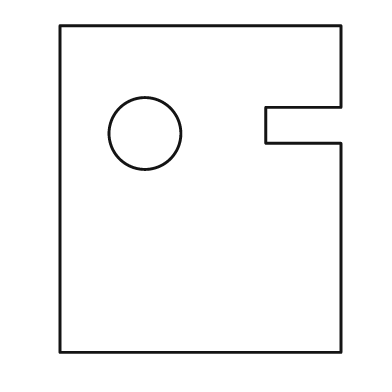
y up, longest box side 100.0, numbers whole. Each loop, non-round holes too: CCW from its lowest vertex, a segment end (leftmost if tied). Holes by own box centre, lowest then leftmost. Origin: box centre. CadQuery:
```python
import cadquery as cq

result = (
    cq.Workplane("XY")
    .moveTo(-43.0, -50.0)
    .lineTo(43.0, -50.0)
    .lineTo(43.0, 14.0)
    .lineTo(20.0, 14.0)
    .lineTo(20.0, 25.0)
    .lineTo(43.0, 25.0)
    .lineTo(43.0, 50.0)
    .lineTo(-43.0, 50.0)
    .close()
    .moveTo(-17.0, 17.0)
    .circle(11.0)
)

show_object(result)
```